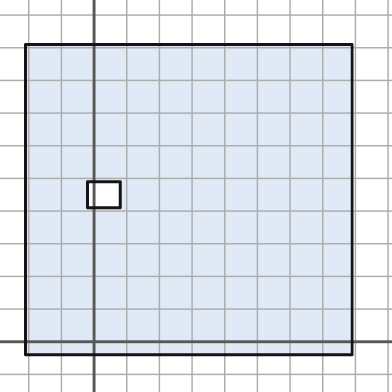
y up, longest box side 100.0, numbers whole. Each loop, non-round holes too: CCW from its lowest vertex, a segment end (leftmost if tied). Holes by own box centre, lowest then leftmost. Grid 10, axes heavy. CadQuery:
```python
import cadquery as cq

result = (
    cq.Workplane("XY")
    .moveTo(-21.0, -4.0)
    .lineTo(79.0, -4.0)
    .lineTo(79.0, 91.0)
    .lineTo(-21.0, 91.0)
    .close()
    .moveTo(-2.0, 41.0)
    .lineTo(8.0, 41.0)
    .lineTo(8.0, 49.0)
    .lineTo(-2.0, 49.0)
    .close()
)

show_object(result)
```